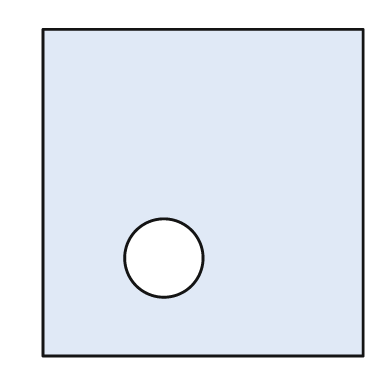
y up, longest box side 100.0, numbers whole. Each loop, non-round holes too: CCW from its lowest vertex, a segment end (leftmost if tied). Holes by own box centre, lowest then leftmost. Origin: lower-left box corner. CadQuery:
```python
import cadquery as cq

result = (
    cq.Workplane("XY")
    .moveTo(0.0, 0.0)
    .lineTo(98.0, 0.0)
    .lineTo(98.0, 100.0)
    .lineTo(0.0, 100.0)
    .close()
    .moveTo(37.0, 30.0)
    .circle(12.0)
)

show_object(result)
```